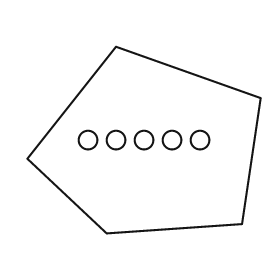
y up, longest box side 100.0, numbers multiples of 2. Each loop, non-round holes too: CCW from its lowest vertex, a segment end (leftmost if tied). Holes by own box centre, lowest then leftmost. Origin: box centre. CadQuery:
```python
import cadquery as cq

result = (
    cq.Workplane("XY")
    .moveTo(-16.0, -40.0)
    .lineTo(42.0, -36.0)
    .lineTo(50.0, 18.0)
    .lineTo(-12.0, 40.0)
    .lineTo(-50.0, -8.0)
    .close()
    .moveTo(-24.0, 0.0)
    .circle(4.0)
    .moveTo(-12.0, 0.0)
    .circle(4.0)
    .moveTo(0.0, 0.0)
    .circle(4.0)
    .moveTo(12.0, 0.0)
    .circle(4.0)
    .moveTo(24.0, 0.0)
    .circle(4.0)
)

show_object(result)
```